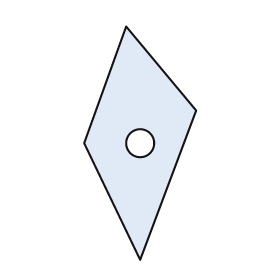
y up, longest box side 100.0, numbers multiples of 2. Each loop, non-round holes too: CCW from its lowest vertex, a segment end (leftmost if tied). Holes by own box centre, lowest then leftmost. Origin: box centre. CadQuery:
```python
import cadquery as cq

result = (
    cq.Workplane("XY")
    .moveTo(0.0, -50.0)
    .lineTo(24.0, 14.0)
    .lineTo(-6.0, 50.0)
    .lineTo(-24.0, 0.0)
    .close()
    .moveTo(0.0, 0.0)
    .circle(6.0)
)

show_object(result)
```